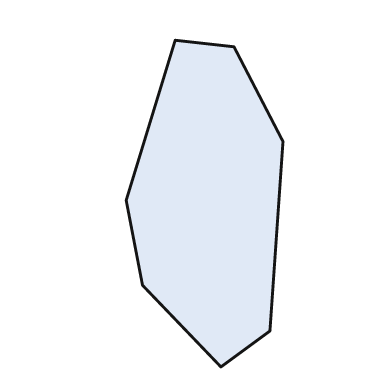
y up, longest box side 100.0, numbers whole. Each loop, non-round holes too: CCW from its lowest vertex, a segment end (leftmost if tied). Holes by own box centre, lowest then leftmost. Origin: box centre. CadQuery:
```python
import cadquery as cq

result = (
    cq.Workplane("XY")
    .moveTo(5.0, -50.0)
    .lineTo(20.0, -39.0)
    .lineTo(24.0, 19.0)
    .lineTo(9.0, 48.0)
    .lineTo(-9.0, 50.0)
    .lineTo(-24.0, 1.0)
    .lineTo(-19.0, -25.0)
    .close()
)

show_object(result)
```